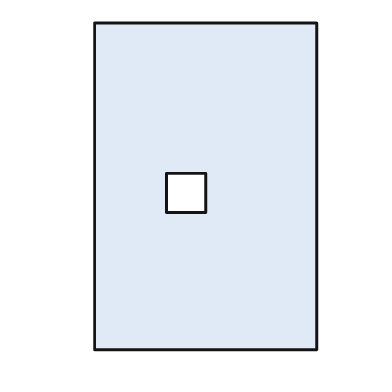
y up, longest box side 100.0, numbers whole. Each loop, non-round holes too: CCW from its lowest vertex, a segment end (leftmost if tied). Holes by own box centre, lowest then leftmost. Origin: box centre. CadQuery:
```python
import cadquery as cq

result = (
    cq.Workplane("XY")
    .moveTo(-34.0, -50.0)
    .lineTo(34.0, -50.0)
    .lineTo(34.0, 50.0)
    .lineTo(-34.0, 50.0)
    .close()
    .moveTo(-12.0, -8.0)
    .lineTo(0.0, -8.0)
    .lineTo(0.0, 4.0)
    .lineTo(-12.0, 4.0)
    .close()
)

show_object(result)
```